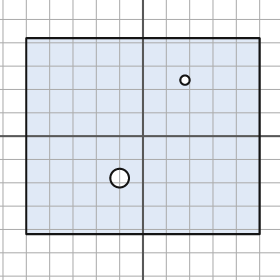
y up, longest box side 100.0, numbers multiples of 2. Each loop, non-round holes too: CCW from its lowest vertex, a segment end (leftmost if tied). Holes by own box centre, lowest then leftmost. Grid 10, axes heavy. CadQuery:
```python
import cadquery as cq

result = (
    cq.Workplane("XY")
    .moveTo(-50.0, -42.0)
    .lineTo(50.0, -42.0)
    .lineTo(50.0, 42.0)
    .lineTo(-50.0, 42.0)
    .close()
    .moveTo(-10.0, -18.0)
    .circle(4.0)
    .moveTo(18.0, 24.0)
    .circle(2.0)
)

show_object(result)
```